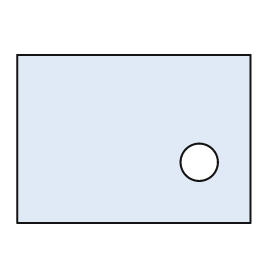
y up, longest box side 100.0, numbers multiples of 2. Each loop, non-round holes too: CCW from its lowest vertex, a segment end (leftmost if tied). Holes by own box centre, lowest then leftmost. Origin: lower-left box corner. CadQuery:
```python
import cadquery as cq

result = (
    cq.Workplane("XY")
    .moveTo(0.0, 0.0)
    .lineTo(100.0, 0.0)
    .lineTo(100.0, 72.0)
    .lineTo(0.0, 72.0)
    .close()
    .moveTo(78.0, 26.0)
    .circle(8.0)
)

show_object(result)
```